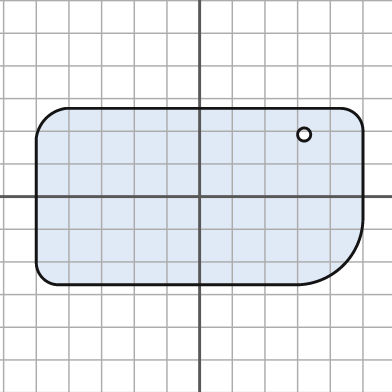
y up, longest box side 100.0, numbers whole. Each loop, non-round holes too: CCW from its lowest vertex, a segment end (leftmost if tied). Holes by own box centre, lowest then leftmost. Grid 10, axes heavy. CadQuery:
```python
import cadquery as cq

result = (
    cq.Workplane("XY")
    .moveTo(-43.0, -27.0)
    .lineTo(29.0, -27.0)
    .threePointArc((44.0, -21.0), (50.0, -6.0))
    .lineTo(50.0, 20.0)
    .threePointArc((48.0, 25.0), (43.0, 27.0))
    .lineTo(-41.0, 27.0)
    .threePointArc((-47.0, 24.0), (-50.0, 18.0))
    .lineTo(-50.0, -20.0)
    .threePointArc((-48.0, -25.0), (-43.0, -27.0))
    .close()
    .moveTo(32.0, 19.0)
    .circle(2.0)
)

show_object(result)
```